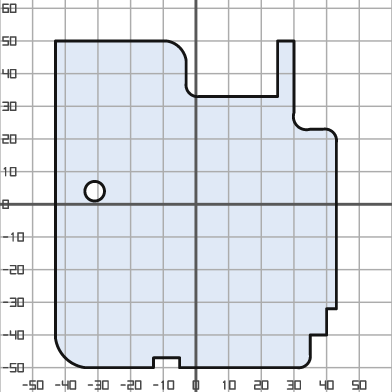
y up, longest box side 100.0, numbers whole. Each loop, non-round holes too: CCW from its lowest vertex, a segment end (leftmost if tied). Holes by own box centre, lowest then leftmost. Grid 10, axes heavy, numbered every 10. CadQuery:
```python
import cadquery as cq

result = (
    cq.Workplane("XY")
    .moveTo(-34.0, -50.0)
    .lineTo(-13.0, -50.0)
    .lineTo(-13.0, -47.0)
    .lineTo(-5.0, -47.0)
    .lineTo(-5.0, -50.0)
    .lineTo(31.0, -50.0)
    .threePointArc((34.0, -49.0), (35.0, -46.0))
    .lineTo(35.0, -40.0)
    .lineTo(40.0, -40.0)
    .lineTo(40.0, -32.0)
    .lineTo(43.0, -32.0)
    .lineTo(43.0, 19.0)
    .threePointArc((42.0, 22.0), (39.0, 23.0))
    .lineTo(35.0, 23.0)
    .threePointArc((31.0, 24.0), (30.0, 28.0))
    .lineTo(30.0, 50.0)
    .lineTo(25.0, 50.0)
    .lineTo(25.0, 33.0)
    .lineTo(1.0, 33.0)
    .threePointArc((-2.0, 34.0), (-3.0, 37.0))
    .lineTo(-3.0, 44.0)
    .threePointArc((-5.0, 48.0), (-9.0, 50.0))
    .lineTo(-43.0, 50.0)
    .lineTo(-43.0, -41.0)
    .threePointArc((-40.0, -47.0), (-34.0, -50.0))
    .close()
    .moveTo(-31.0, 4.0)
    .circle(3.0)
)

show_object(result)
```